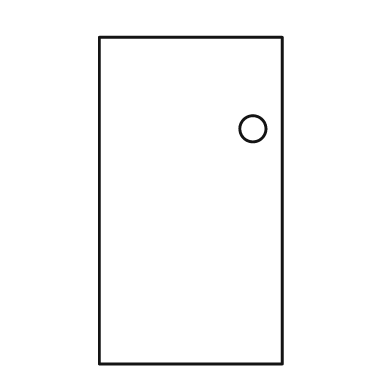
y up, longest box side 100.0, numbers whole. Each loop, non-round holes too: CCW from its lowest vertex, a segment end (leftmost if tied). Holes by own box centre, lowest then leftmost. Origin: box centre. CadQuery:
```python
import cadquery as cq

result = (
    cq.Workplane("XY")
    .moveTo(-28.0, -50.0)
    .lineTo(28.0, -50.0)
    .lineTo(28.0, 50.0)
    .lineTo(-28.0, 50.0)
    .close()
    .moveTo(19.0, 22.0)
    .circle(4.0)
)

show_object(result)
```